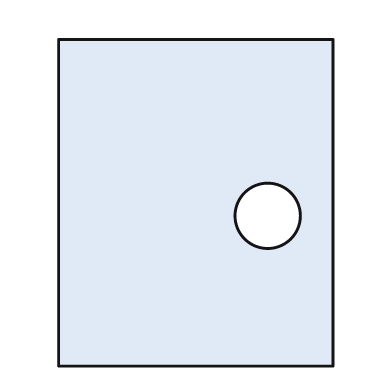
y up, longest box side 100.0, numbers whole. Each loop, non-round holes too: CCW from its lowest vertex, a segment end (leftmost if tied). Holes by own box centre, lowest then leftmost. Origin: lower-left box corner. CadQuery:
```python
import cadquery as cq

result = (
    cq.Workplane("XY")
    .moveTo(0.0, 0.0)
    .lineTo(84.0, 0.0)
    .lineTo(84.0, 100.0)
    .lineTo(0.0, 100.0)
    .close()
    .moveTo(64.0, 46.0)
    .circle(10.0)
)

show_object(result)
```